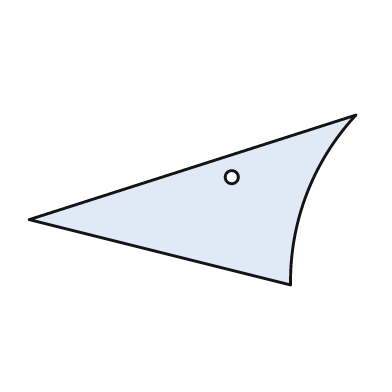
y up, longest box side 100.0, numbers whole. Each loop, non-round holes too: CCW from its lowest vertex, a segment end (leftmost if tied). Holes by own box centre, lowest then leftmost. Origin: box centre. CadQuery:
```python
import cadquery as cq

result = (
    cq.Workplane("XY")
    .moveTo(30.0, -26.0)
    .threePointArc((35.0, 2.0), (50.0, 26.0))
    .lineTo(-50.0, -6.0)
    .close()
    .moveTo(12.0, 7.0)
    .circle(2.0)
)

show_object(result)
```